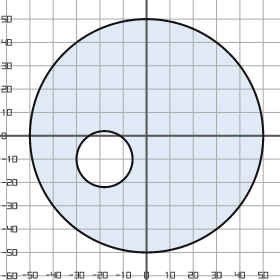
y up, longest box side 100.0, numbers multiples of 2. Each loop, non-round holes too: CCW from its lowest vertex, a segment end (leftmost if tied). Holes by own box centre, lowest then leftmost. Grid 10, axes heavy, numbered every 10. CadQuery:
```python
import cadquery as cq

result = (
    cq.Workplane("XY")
    .moveTo(0.0, 0.0)
    .circle(50.0)
    .moveTo(-18.0, -10.0)
    .circle(12.0)
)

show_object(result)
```